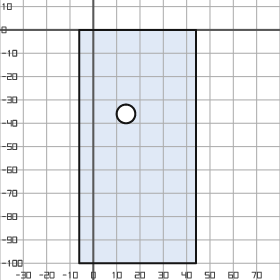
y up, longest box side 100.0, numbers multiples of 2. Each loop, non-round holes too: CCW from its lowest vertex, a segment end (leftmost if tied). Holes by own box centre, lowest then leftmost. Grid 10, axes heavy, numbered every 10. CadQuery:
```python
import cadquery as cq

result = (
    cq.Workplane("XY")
    .moveTo(-6.0, -100.0)
    .lineTo(44.0, -100.0)
    .lineTo(44.0, 0.0)
    .lineTo(-6.0, 0.0)
    .close()
    .moveTo(14.0, -36.0)
    .circle(4.0)
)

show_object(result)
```